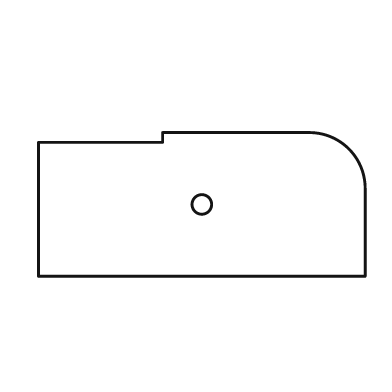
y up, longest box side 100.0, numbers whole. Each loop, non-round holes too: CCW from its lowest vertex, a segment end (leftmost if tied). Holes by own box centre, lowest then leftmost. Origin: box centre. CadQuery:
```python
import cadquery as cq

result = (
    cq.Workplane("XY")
    .moveTo(-50.0, -22.0)
    .lineTo(50.0, -22.0)
    .lineTo(50.0, 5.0)
    .threePointArc((45.0, 17.0), (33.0, 22.0))
    .lineTo(-12.0, 22.0)
    .lineTo(-12.0, 19.0)
    .lineTo(-50.0, 19.0)
    .close()
    .moveTo(0.0, 0.0)
    .circle(3.0)
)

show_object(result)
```